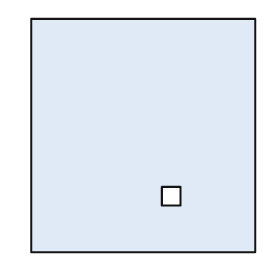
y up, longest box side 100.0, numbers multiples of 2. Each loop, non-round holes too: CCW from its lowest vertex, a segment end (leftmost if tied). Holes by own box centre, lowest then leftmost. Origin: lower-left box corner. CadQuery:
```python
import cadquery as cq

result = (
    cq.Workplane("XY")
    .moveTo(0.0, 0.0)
    .lineTo(96.0, 0.0)
    .lineTo(96.0, 100.0)
    .lineTo(0.0, 100.0)
    .close()
    .moveTo(56.0, 20.0)
    .lineTo(64.0, 20.0)
    .lineTo(64.0, 28.0)
    .lineTo(56.0, 28.0)
    .close()
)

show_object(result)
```